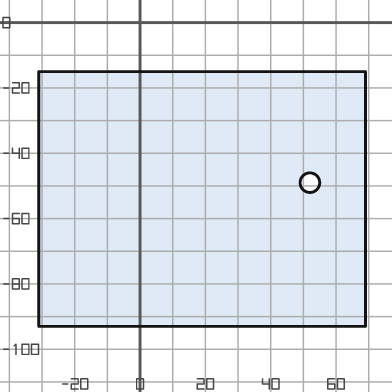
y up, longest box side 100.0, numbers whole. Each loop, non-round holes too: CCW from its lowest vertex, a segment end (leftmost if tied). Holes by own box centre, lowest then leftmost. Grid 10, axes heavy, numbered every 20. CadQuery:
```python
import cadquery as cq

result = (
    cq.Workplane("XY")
    .moveTo(-31.0, -93.0)
    .lineTo(69.0, -93.0)
    .lineTo(69.0, -15.0)
    .lineTo(-31.0, -15.0)
    .close()
    .moveTo(52.0, -49.0)
    .circle(3.0)
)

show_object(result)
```